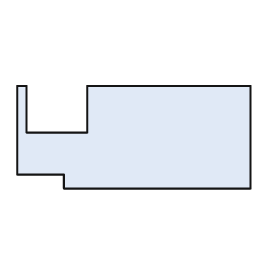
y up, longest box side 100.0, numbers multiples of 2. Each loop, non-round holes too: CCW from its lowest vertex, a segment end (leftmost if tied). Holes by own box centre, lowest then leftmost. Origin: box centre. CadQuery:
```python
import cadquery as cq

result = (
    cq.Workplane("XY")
    .moveTo(-30.0, -22.0)
    .lineTo(50.0, -22.0)
    .lineTo(50.0, 22.0)
    .lineTo(-20.0, 22.0)
    .lineTo(-20.0, 2.0)
    .lineTo(-46.0, 2.0)
    .lineTo(-46.0, 22.0)
    .lineTo(-50.0, 22.0)
    .lineTo(-50.0, -16.0)
    .lineTo(-30.0, -16.0)
    .close()
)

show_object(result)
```